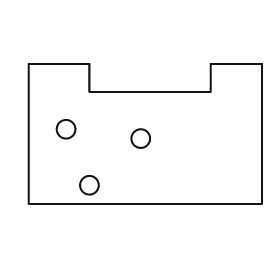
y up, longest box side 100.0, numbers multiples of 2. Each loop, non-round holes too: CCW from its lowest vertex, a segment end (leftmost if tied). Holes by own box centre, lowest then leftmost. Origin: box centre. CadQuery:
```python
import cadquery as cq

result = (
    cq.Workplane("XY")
    .moveTo(-50.0, -30.0)
    .lineTo(50.0, -30.0)
    .lineTo(50.0, 30.0)
    .lineTo(28.0, 30.0)
    .lineTo(28.0, 18.0)
    .lineTo(-24.0, 18.0)
    .lineTo(-24.0, 30.0)
    .lineTo(-50.0, 30.0)
    .close()
    .moveTo(-24.0, -22.0)
    .circle(4.0)
    .moveTo(-2.0, -2.0)
    .circle(4.0)
    .moveTo(-34.0, 2.0)
    .circle(4.0)
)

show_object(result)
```